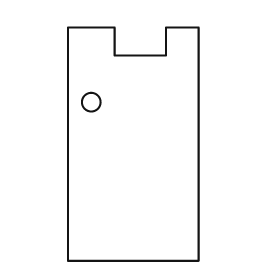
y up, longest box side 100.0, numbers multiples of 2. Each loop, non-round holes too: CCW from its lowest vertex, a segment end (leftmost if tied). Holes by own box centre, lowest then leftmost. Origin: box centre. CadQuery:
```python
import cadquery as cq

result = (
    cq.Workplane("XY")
    .moveTo(-28.0, -50.0)
    .lineTo(28.0, -50.0)
    .lineTo(28.0, 50.0)
    .lineTo(14.0, 50.0)
    .lineTo(14.0, 38.0)
    .lineTo(-8.0, 38.0)
    .lineTo(-8.0, 50.0)
    .lineTo(-28.0, 50.0)
    .close()
    .moveTo(-18.0, 18.0)
    .circle(4.0)
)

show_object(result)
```